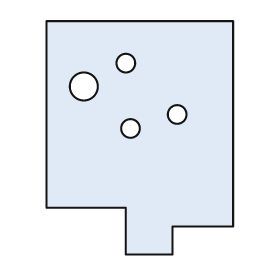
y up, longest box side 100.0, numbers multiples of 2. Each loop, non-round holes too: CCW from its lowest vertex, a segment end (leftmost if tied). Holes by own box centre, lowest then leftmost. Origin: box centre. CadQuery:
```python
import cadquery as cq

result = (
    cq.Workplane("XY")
    .moveTo(-6.0, -50.0)
    .lineTo(14.0, -50.0)
    .lineTo(14.0, -38.0)
    .lineTo(40.0, -38.0)
    .lineTo(40.0, 50.0)
    .lineTo(-40.0, 50.0)
    .lineTo(-40.0, -30.0)
    .lineTo(-6.0, -30.0)
    .close()
    .moveTo(-4.0, 4.0)
    .circle(4.0)
    .moveTo(16.0, 10.0)
    .circle(4.0)
    .moveTo(-24.0, 22.0)
    .circle(6.0)
    .moveTo(-6.0, 32.0)
    .circle(4.0)
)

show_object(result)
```